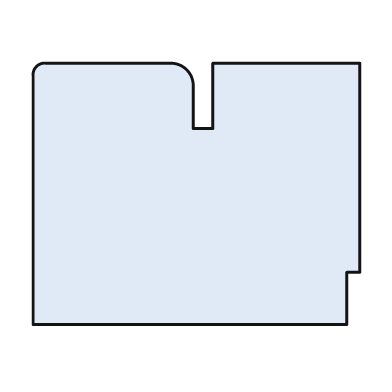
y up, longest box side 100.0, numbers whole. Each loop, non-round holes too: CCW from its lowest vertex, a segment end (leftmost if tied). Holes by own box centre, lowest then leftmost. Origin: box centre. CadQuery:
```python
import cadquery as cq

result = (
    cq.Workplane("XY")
    .moveTo(-50.0, -40.0)
    .lineTo(46.0, -40.0)
    .lineTo(46.0, -24.0)
    .lineTo(50.0, -24.0)
    .lineTo(50.0, 40.0)
    .lineTo(5.0, 40.0)
    .lineTo(5.0, 20.0)
    .lineTo(-1.0, 20.0)
    .lineTo(-1.0, 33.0)
    .threePointArc((-3.0, 38.0), (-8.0, 40.0))
    .lineTo(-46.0, 40.0)
    .threePointArc((-49.0, 39.0), (-50.0, 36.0))
    .close()
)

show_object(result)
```